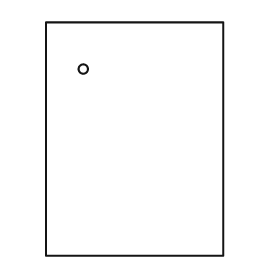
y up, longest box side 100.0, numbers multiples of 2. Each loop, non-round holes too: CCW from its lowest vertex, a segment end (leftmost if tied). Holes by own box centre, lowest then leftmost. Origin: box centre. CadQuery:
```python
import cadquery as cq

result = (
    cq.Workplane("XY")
    .moveTo(-38.0, -50.0)
    .lineTo(38.0, -50.0)
    .lineTo(38.0, 50.0)
    .lineTo(-38.0, 50.0)
    .close()
    .moveTo(-22.0, 30.0)
    .circle(2.0)
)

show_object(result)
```